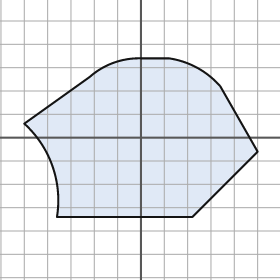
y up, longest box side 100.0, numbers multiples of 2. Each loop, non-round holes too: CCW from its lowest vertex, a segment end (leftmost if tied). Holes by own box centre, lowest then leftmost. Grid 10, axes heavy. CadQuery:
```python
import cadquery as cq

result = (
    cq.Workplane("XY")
    .moveTo(-36.0, -34.0)
    .lineTo(22.0, -34.0)
    .lineTo(50.0, -6.0)
    .lineTo(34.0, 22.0)
    .threePointArc((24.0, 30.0), (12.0, 34.0))
    .lineTo(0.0, 34.0)
    .threePointArc((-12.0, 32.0), (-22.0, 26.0))
    .lineTo(-50.0, 6.0)
    .threePointArc((-38.0, -12.0), (-36.0, -34.0))
    .close()
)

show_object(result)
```